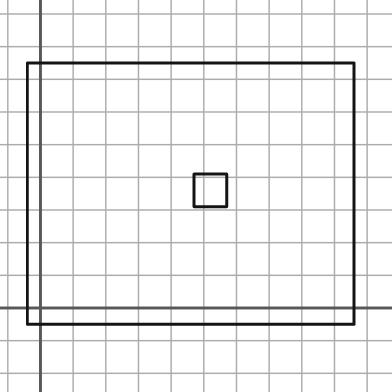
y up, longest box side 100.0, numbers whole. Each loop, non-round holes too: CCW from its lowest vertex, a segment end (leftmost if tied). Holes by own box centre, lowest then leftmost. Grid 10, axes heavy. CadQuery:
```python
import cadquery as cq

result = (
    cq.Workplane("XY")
    .moveTo(-4.0, -5.0)
    .lineTo(96.0, -5.0)
    .lineTo(96.0, 75.0)
    .lineTo(-4.0, 75.0)
    .close()
    .moveTo(47.0, 31.0)
    .lineTo(57.0, 31.0)
    .lineTo(57.0, 41.0)
    .lineTo(47.0, 41.0)
    .close()
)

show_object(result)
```